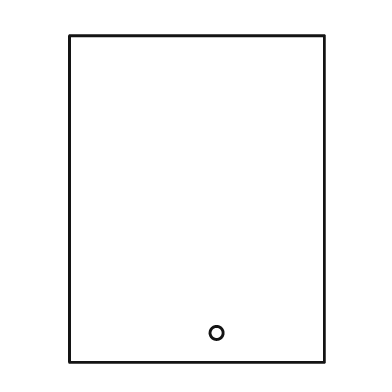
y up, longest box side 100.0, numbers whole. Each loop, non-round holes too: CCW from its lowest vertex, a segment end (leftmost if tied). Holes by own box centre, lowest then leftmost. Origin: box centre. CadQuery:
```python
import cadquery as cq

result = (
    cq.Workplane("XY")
    .moveTo(-39.0, -50.0)
    .lineTo(39.0, -50.0)
    .lineTo(39.0, 50.0)
    .lineTo(-39.0, 50.0)
    .close()
    .moveTo(6.0, -41.0)
    .circle(2.0)
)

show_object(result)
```